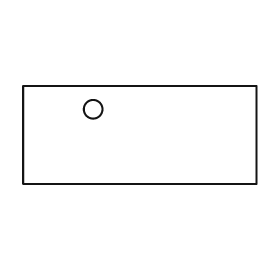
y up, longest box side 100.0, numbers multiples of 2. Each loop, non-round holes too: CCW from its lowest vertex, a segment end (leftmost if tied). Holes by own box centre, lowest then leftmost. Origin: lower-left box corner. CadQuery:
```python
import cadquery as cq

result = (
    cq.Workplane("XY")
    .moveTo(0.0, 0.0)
    .lineTo(100.0, 0.0)
    .lineTo(100.0, 42.0)
    .lineTo(0.0, 42.0)
    .close()
    .moveTo(30.0, 32.0)
    .circle(4.0)
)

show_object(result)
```